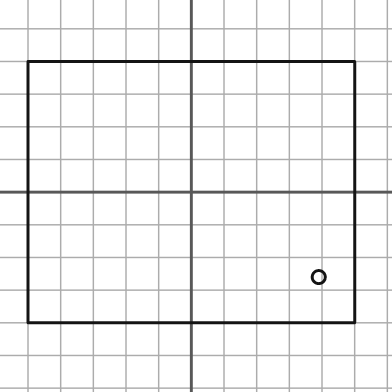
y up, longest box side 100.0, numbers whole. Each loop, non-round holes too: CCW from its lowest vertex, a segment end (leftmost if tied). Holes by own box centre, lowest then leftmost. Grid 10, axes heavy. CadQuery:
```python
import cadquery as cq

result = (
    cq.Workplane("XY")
    .moveTo(-50.0, -40.0)
    .lineTo(50.0, -40.0)
    .lineTo(50.0, 40.0)
    .lineTo(-50.0, 40.0)
    .close()
    .moveTo(39.0, -26.0)
    .circle(2.0)
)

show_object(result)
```